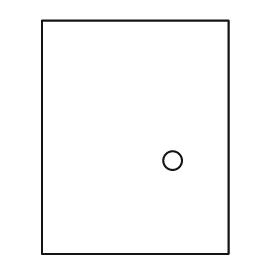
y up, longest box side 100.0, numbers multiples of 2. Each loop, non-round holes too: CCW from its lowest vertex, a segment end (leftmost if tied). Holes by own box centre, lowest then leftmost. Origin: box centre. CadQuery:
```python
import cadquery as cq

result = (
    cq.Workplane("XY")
    .moveTo(-40.0, -50.0)
    .lineTo(40.0, -50.0)
    .lineTo(40.0, 50.0)
    .lineTo(-40.0, 50.0)
    .close()
    .moveTo(16.0, -10.0)
    .circle(4.0)
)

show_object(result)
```